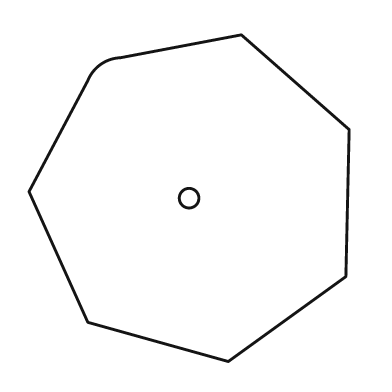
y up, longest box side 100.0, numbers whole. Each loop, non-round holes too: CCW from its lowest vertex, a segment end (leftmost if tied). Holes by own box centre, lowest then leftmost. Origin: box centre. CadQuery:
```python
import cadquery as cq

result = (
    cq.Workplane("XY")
    .moveTo(12.0, -50.0)
    .lineTo(48.0, -24.0)
    .lineTo(49.0, 21.0)
    .lineTo(16.0, 50.0)
    .lineTo(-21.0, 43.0)
    .threePointArc((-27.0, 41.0), (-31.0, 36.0))
    .lineTo(-49.0, 2.0)
    .lineTo(-31.0, -38.0)
    .close()
    .moveTo(0.0, 0.0)
    .circle(3.0)
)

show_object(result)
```